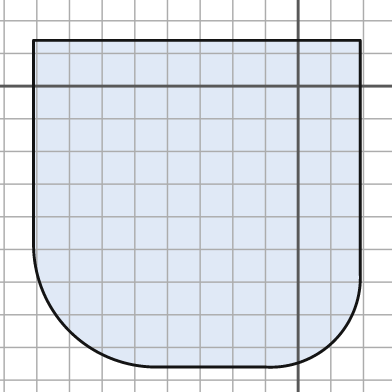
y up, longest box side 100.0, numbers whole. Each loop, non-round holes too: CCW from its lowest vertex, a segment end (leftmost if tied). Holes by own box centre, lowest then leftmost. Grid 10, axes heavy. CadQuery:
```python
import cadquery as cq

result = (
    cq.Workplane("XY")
    .moveTo(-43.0, -86.0)
    .lineTo(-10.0, -86.0)
    .threePointArc((11.0, -78.0), (19.0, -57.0))
    .lineTo(19.0, 14.0)
    .lineTo(-81.0, 14.0)
    .lineTo(-81.0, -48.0)
    .threePointArc((-70.0, -75.0), (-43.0, -86.0))
    .close()
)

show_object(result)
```